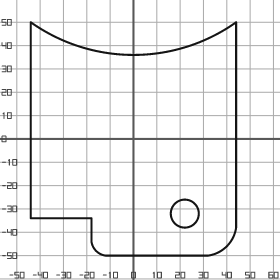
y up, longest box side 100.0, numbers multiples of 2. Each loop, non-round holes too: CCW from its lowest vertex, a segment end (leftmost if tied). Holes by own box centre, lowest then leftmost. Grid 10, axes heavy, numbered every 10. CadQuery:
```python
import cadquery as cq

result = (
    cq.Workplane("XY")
    .moveTo(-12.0, -50.0)
    .lineTo(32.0, -50.0)
    .threePointArc((40.0, -46.0), (44.0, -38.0))
    .lineTo(44.0, 50.0)
    .threePointArc((0.0, 36.0), (-44.0, 50.0))
    .lineTo(-44.0, -34.0)
    .lineTo(-18.0, -34.0)
    .lineTo(-18.0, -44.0)
    .threePointArc((-16.0, -48.0), (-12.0, -50.0))
    .close()
    .moveTo(22.0, -32.0)
    .circle(6.0)
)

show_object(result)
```